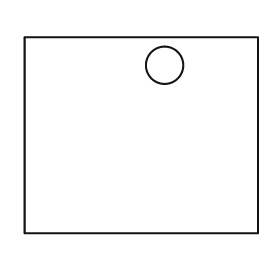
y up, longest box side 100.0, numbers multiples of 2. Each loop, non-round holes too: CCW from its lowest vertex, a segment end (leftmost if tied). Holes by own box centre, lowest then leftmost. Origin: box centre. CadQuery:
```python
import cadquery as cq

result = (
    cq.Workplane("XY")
    .moveTo(-50.0, -42.0)
    .lineTo(50.0, -42.0)
    .lineTo(50.0, 42.0)
    .lineTo(-50.0, 42.0)
    .close()
    .moveTo(10.0, 30.0)
    .circle(8.0)
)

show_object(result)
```